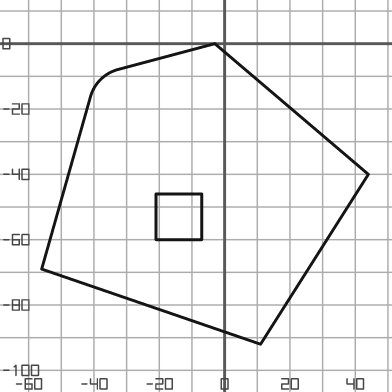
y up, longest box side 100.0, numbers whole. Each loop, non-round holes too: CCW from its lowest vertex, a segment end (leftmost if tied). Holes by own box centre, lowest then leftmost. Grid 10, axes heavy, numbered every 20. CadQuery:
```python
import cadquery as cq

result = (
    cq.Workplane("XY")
    .moveTo(11.0, -92.0)
    .lineTo(44.0, -40.0)
    .lineTo(-3.0, 0.0)
    .lineTo(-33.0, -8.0)
    .threePointArc((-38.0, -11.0), (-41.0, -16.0))
    .lineTo(-56.0, -69.0)
    .close()
    .moveTo(-21.0, -60.0)
    .lineTo(-7.0, -60.0)
    .lineTo(-7.0, -46.0)
    .lineTo(-21.0, -46.0)
    .close()
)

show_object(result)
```